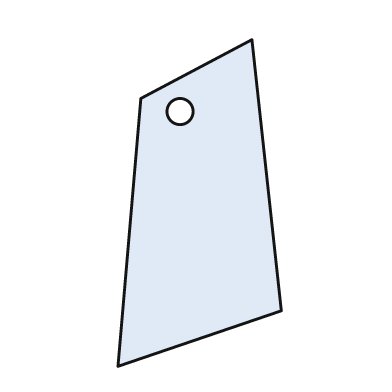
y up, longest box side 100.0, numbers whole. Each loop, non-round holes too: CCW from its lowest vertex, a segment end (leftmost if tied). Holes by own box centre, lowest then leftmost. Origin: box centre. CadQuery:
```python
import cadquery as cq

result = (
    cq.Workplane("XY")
    .moveTo(-25.0, -50.0)
    .lineTo(25.0, -33.0)
    .lineTo(16.0, 50.0)
    .lineTo(-18.0, 32.0)
    .close()
    .moveTo(-6.0, 28.0)
    .circle(4.0)
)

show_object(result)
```